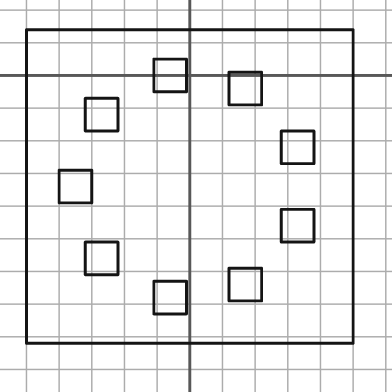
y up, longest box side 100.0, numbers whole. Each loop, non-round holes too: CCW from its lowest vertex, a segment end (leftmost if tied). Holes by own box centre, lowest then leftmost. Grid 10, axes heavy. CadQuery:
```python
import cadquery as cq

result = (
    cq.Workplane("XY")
    .moveTo(-50.0, -82.0)
    .lineTo(50.0, -82.0)
    .lineTo(50.0, 14.0)
    .lineTo(-50.0, 14.0)
    .close()
    .moveTo(-11.0, -73.0)
    .lineTo(-1.0, -73.0)
    .lineTo(-1.0, -63.0)
    .lineTo(-11.0, -63.0)
    .close()
    .moveTo(12.0, -69.0)
    .lineTo(22.0, -69.0)
    .lineTo(22.0, -59.0)
    .lineTo(12.0, -59.0)
    .close()
    .moveTo(-32.0, -61.0)
    .lineTo(-22.0, -61.0)
    .lineTo(-22.0, -51.0)
    .lineTo(-32.0, -51.0)
    .close()
    .moveTo(28.0, -51.0)
    .lineTo(38.0, -51.0)
    .lineTo(38.0, -41.0)
    .lineTo(28.0, -41.0)
    .close()
    .moveTo(-40.0, -39.0)
    .lineTo(-30.0, -39.0)
    .lineTo(-30.0, -29.0)
    .lineTo(-40.0, -29.0)
    .close()
    .moveTo(28.0, -27.0)
    .lineTo(38.0, -27.0)
    .lineTo(38.0, -17.0)
    .lineTo(28.0, -17.0)
    .close()
    .moveTo(-32.0, -17.0)
    .lineTo(-22.0, -17.0)
    .lineTo(-22.0, -7.0)
    .lineTo(-32.0, -7.0)
    .close()
    .moveTo(12.0, -9.0)
    .lineTo(22.0, -9.0)
    .lineTo(22.0, 1.0)
    .lineTo(12.0, 1.0)
    .close()
    .moveTo(-11.0, -5.0)
    .lineTo(-1.0, -5.0)
    .lineTo(-1.0, 5.0)
    .lineTo(-11.0, 5.0)
    .close()
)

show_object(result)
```